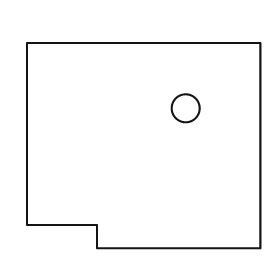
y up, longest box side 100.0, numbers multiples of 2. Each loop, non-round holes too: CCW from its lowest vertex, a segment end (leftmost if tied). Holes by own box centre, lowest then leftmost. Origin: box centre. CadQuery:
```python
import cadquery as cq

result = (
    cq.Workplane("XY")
    .moveTo(-20.0, -44.0)
    .lineTo(50.0, -44.0)
    .lineTo(50.0, 44.0)
    .lineTo(-50.0, 44.0)
    .lineTo(-50.0, -34.0)
    .lineTo(-20.0, -34.0)
    .close()
    .moveTo(18.0, 16.0)
    .circle(6.0)
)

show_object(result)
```